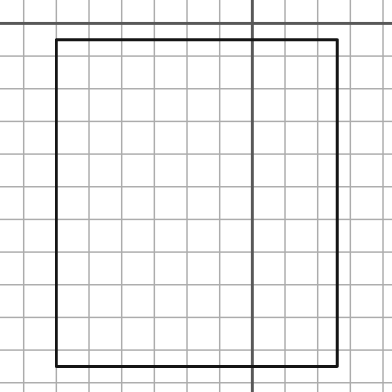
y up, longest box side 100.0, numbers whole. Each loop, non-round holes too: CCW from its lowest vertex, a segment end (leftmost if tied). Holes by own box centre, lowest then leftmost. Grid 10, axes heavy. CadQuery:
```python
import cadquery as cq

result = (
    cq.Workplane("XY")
    .moveTo(-60.0, -105.0)
    .lineTo(26.0, -105.0)
    .lineTo(26.0, -5.0)
    .lineTo(-60.0, -5.0)
    .close()
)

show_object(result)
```